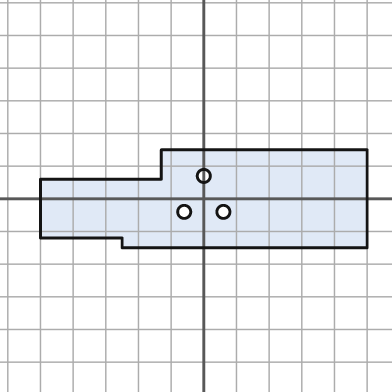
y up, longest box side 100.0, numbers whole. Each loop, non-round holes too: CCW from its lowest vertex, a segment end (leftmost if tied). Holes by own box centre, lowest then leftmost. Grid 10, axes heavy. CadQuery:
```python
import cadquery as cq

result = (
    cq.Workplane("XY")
    .moveTo(-25.0, -15.0)
    .lineTo(50.0, -15.0)
    .lineTo(50.0, 15.0)
    .lineTo(-13.0, 15.0)
    .lineTo(-13.0, 6.0)
    .lineTo(-50.0, 6.0)
    .lineTo(-50.0, -12.0)
    .lineTo(-25.0, -12.0)
    .close()
    .moveTo(-6.0, -4.0)
    .circle(2.0)
    .moveTo(6.0, -4.0)
    .circle(2.0)
    .moveTo(0.0, 7.0)
    .circle(2.0)
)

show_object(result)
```